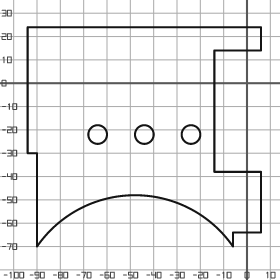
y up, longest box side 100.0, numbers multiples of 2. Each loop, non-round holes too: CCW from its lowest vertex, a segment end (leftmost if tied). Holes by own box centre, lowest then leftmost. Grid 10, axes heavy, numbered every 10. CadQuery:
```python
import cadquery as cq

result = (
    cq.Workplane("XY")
    .moveTo(-90.0, -70.0)
    .threePointArc((-48.0, -48.0), (-6.0, -70.0))
    .lineTo(-6.0, -64.0)
    .lineTo(6.0, -64.0)
    .lineTo(6.0, -38.0)
    .lineTo(-14.0, -38.0)
    .lineTo(-14.0, 14.0)
    .lineTo(6.0, 14.0)
    .lineTo(6.0, 24.0)
    .lineTo(-94.0, 24.0)
    .lineTo(-94.0, -30.0)
    .lineTo(-90.0, -30.0)
    .close()
    .moveTo(-64.0, -22.0)
    .circle(4.0)
    .moveTo(-44.0, -22.0)
    .circle(4.0)
    .moveTo(-24.0, -22.0)
    .circle(4.0)
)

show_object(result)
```